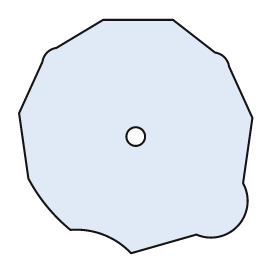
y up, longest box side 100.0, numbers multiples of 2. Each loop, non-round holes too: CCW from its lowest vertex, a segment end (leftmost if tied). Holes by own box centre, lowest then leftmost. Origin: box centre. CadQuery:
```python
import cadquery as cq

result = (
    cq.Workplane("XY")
    .moveTo(-2.0, -50.0)
    .lineTo(26.0, -42.0)
    .threePointArc((44.0, -38.0), (46.0, -20.0))
    .lineTo(50.0, 8.0)
    .lineTo(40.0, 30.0)
    .threePointArc((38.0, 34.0), (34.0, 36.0))
    .lineTo(16.0, 50.0)
    .lineTo(-14.0, 50.0)
    .lineTo(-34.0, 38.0)
    .threePointArc((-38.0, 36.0), (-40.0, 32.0))
    .lineTo(-50.0, 10.0)
    .lineTo(-46.0, -18.0)
    .threePointArc((-38.0, -30.0), (-28.0, -40.0))
    .threePointArc((-14.0, -42.0), (-2.0, -50.0))
    .close()
    .moveTo(0.0, 0.0)
    .circle(4.0)
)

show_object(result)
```